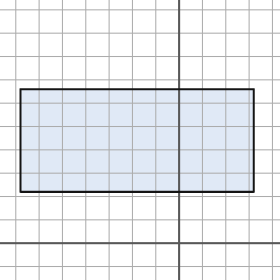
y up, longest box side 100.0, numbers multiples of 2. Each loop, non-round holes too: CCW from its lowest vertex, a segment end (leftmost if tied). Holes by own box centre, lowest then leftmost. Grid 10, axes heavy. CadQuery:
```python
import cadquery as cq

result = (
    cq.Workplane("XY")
    .moveTo(-68.0, 22.0)
    .lineTo(32.0, 22.0)
    .lineTo(32.0, 66.0)
    .lineTo(-68.0, 66.0)
    .close()
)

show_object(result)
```